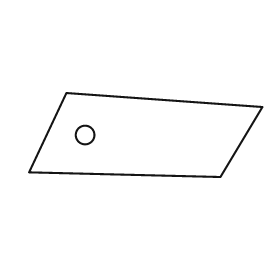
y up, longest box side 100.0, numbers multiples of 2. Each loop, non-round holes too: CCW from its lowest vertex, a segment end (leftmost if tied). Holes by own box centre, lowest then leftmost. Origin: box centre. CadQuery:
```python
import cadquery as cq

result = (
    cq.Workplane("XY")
    .moveTo(32.0, -18.0)
    .lineTo(50.0, 12.0)
    .lineTo(-34.0, 18.0)
    .lineTo(-50.0, -16.0)
    .close()
    .moveTo(-26.0, 0.0)
    .circle(4.0)
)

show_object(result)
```